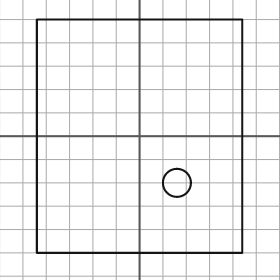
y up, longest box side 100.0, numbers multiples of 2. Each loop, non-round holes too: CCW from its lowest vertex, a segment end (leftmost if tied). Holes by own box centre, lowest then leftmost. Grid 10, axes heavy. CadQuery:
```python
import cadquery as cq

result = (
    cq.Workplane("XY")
    .moveTo(-44.0, -50.0)
    .lineTo(44.0, -50.0)
    .lineTo(44.0, 50.0)
    .lineTo(-44.0, 50.0)
    .close()
    .moveTo(16.0, -20.0)
    .circle(6.0)
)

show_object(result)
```